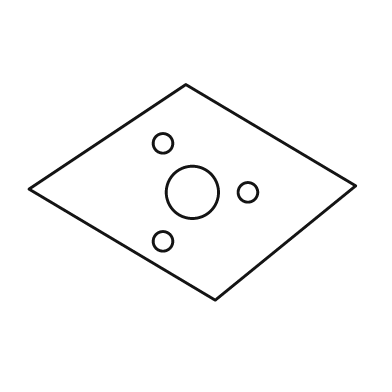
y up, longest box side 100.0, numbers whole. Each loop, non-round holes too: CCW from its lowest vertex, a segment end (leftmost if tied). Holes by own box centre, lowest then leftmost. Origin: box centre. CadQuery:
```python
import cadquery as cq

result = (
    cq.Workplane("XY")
    .moveTo(7.0, -33.0)
    .lineTo(50.0, 2.0)
    .lineTo(-2.0, 33.0)
    .lineTo(-50.0, 1.0)
    .close()
    .moveTo(-9.0, -15.0)
    .circle(3.0)
    .moveTo(0.0, 0.0)
    .circle(8.0)
    .moveTo(17.0, 0.0)
    .circle(3.0)
    .moveTo(-9.0, 15.0)
    .circle(3.0)
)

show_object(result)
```